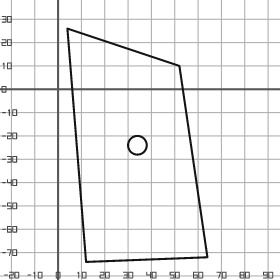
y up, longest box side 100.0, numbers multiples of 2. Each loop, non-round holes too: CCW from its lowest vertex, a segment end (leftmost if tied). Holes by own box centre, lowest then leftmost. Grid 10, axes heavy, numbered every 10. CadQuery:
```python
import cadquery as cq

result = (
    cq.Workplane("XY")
    .moveTo(12.0, -74.0)
    .lineTo(64.0, -72.0)
    .lineTo(52.0, 10.0)
    .lineTo(4.0, 26.0)
    .close()
    .moveTo(34.0, -24.0)
    .circle(4.0)
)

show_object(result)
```